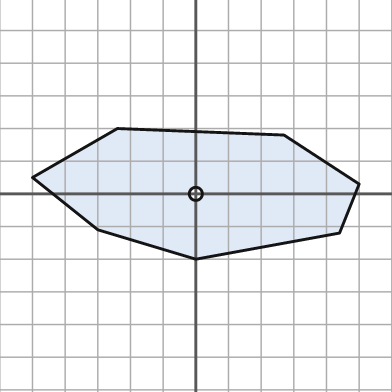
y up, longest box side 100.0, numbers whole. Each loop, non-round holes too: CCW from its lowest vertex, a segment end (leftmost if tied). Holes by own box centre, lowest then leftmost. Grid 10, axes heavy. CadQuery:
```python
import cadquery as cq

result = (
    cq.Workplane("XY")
    .moveTo(0.0, -20.0)
    .lineTo(44.0, -12.0)
    .lineTo(50.0, 3.0)
    .lineTo(27.0, 18.0)
    .lineTo(-24.0, 20.0)
    .lineTo(-50.0, 5.0)
    .lineTo(-30.0, -11.0)
    .close()
    .moveTo(0.0, 0.0)
    .circle(2.0)
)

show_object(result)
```